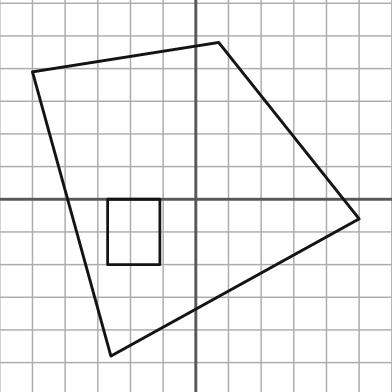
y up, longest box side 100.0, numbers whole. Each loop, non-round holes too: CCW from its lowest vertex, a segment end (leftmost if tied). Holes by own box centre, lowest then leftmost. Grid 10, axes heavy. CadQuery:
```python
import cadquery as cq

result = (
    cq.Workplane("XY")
    .moveTo(-26.0, -48.0)
    .lineTo(50.0, -6.0)
    .lineTo(7.0, 48.0)
    .lineTo(-50.0, 39.0)
    .close()
    .moveTo(-27.0, -20.0)
    .lineTo(-11.0, -20.0)
    .lineTo(-11.0, 0.0)
    .lineTo(-27.0, 0.0)
    .close()
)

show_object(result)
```